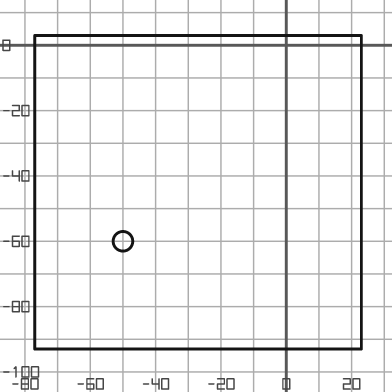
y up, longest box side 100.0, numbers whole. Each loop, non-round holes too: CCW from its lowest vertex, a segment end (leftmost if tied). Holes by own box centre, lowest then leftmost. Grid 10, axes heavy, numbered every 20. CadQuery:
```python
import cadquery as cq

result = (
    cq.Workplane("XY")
    .moveTo(-77.0, -93.0)
    .lineTo(23.0, -93.0)
    .lineTo(23.0, 3.0)
    .lineTo(-77.0, 3.0)
    .close()
    .moveTo(-50.0, -60.0)
    .circle(3.0)
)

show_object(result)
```